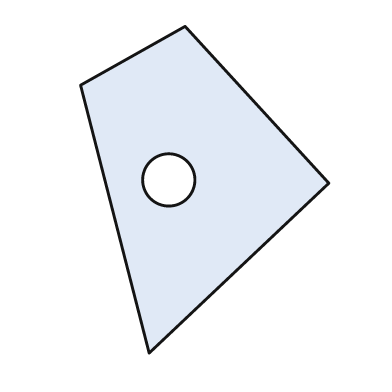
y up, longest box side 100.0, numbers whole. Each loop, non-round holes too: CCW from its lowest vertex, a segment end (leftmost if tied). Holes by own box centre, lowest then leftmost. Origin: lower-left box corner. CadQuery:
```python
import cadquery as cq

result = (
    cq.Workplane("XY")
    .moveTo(21.0, 0.0)
    .lineTo(76.0, 52.0)
    .lineTo(32.0, 100.0)
    .lineTo(0.0, 82.0)
    .close()
    .moveTo(27.0, 53.0)
    .circle(8.0)
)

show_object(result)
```